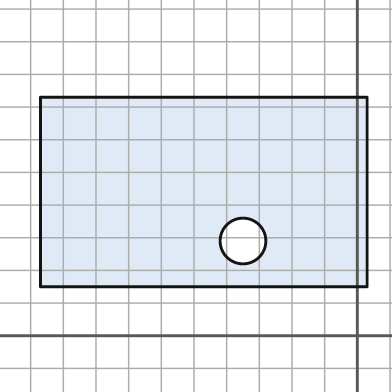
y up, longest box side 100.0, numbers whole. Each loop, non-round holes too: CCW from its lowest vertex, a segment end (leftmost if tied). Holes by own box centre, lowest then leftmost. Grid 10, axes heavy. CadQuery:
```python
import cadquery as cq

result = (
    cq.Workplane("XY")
    .moveTo(-97.0, 15.0)
    .lineTo(3.0, 15.0)
    .lineTo(3.0, 73.0)
    .lineTo(-97.0, 73.0)
    .close()
    .moveTo(-35.0, 29.0)
    .circle(7.0)
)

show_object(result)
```